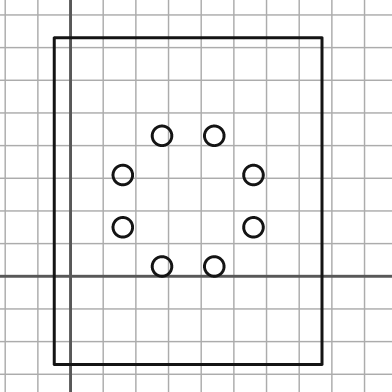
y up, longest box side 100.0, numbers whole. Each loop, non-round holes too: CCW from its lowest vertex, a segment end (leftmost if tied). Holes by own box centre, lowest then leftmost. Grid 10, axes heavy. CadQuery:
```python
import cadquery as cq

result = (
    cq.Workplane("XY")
    .moveTo(-5.0, -27.0)
    .lineTo(77.0, -27.0)
    .lineTo(77.0, 73.0)
    .lineTo(-5.0, 73.0)
    .close()
    .moveTo(28.0, 3.0)
    .circle(3.0)
    .moveTo(44.0, 3.0)
    .circle(3.0)
    .moveTo(16.0, 15.0)
    .circle(3.0)
    .moveTo(56.0, 15.0)
    .circle(3.0)
    .moveTo(16.0, 31.0)
    .circle(3.0)
    .moveTo(56.0, 31.0)
    .circle(3.0)
    .moveTo(28.0, 43.0)
    .circle(3.0)
    .moveTo(44.0, 43.0)
    .circle(3.0)
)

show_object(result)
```